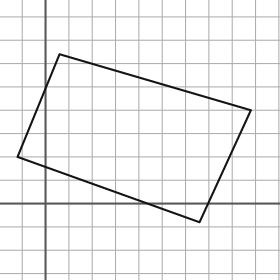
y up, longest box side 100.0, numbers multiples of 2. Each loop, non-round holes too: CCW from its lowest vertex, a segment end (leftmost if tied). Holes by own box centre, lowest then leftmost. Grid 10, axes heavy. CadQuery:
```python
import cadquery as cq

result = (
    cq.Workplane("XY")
    .moveTo(66.0, -8.0)
    .lineTo(88.0, 40.0)
    .lineTo(6.0, 64.0)
    .lineTo(-12.0, 20.0)
    .close()
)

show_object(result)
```